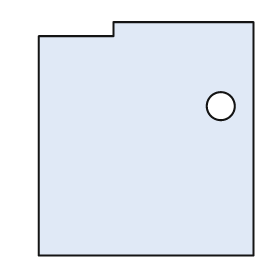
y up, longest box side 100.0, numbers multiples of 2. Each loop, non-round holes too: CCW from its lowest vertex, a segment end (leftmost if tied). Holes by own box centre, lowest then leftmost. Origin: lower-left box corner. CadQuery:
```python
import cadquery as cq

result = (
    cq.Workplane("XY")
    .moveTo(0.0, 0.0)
    .lineTo(92.0, 0.0)
    .lineTo(92.0, 100.0)
    .lineTo(32.0, 100.0)
    .lineTo(32.0, 94.0)
    .lineTo(0.0, 94.0)
    .close()
    .moveTo(78.0, 64.0)
    .circle(6.0)
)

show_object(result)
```